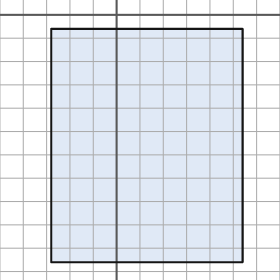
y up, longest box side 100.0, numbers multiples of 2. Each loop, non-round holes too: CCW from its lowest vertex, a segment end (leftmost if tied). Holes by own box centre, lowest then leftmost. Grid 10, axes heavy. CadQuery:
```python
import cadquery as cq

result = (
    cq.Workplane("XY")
    .moveTo(-28.0, -106.0)
    .lineTo(54.0, -106.0)
    .lineTo(54.0, -6.0)
    .lineTo(-28.0, -6.0)
    .close()
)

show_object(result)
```